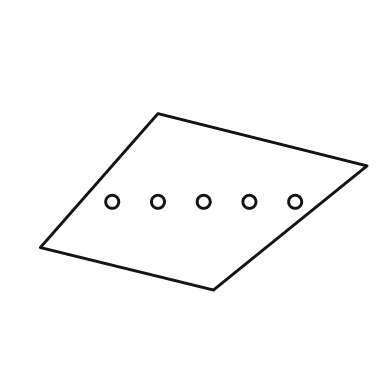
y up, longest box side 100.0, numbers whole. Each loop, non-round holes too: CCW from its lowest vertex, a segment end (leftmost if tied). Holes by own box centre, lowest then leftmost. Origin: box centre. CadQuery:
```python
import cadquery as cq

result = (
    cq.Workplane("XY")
    .moveTo(3.0, -27.0)
    .lineTo(50.0, 11.0)
    .lineTo(-14.0, 27.0)
    .lineTo(-50.0, -14.0)
    .close()
    .moveTo(-28.0, 0.0)
    .circle(2.0)
    .moveTo(-14.0, 0.0)
    .circle(2.0)
    .moveTo(0.0, 0.0)
    .circle(2.0)
    .moveTo(14.0, 0.0)
    .circle(2.0)
    .moveTo(28.0, 0.0)
    .circle(2.0)
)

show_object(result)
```